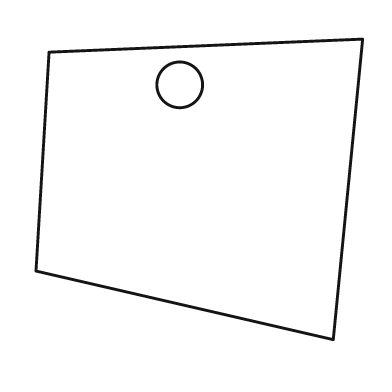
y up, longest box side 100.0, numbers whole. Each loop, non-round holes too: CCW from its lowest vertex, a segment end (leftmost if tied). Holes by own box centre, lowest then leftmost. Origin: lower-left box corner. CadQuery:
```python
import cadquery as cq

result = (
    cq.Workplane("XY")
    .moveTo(91.0, 0.0)
    .lineTo(100.0, 92.0)
    .lineTo(4.0, 88.0)
    .lineTo(0.0, 21.0)
    .close()
    .moveTo(44.0, 78.0)
    .circle(7.0)
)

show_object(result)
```